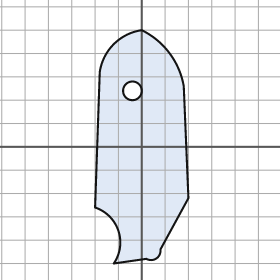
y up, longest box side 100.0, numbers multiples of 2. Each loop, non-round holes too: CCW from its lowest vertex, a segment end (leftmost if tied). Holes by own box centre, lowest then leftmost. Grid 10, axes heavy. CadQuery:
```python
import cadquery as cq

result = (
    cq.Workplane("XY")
    .moveTo(-12.0, -50.0)
    .lineTo(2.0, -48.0)
    .threePointArc((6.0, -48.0), (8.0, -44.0))
    .lineTo(20.0, -22.0)
    .lineTo(18.0, 26.0)
    .threePointArc((12.0, 40.0), (0.0, 50.0))
    .threePointArc((-12.0, 44.0), (-18.0, 32.0))
    .lineTo(-20.0, -26.0)
    .threePointArc((-10.0, -36.0), (-12.0, -50.0))
    .close()
    .moveTo(-4.0, 24.0)
    .circle(4.0)
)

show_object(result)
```